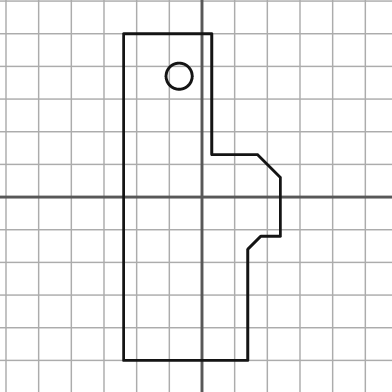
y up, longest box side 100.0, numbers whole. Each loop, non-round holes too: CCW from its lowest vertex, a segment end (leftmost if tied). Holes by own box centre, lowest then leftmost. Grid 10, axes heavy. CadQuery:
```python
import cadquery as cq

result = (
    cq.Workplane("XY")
    .moveTo(-24.0, -50.0)
    .lineTo(14.0, -50.0)
    .lineTo(14.0, -16.0)
    .lineTo(18.0, -12.0)
    .lineTo(24.0, -12.0)
    .lineTo(24.0, 6.0)
    .lineTo(17.0, 13.0)
    .lineTo(3.0, 13.0)
    .lineTo(3.0, 50.0)
    .lineTo(-24.0, 50.0)
    .close()
    .moveTo(-7.0, 37.0)
    .circle(4.0)
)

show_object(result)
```